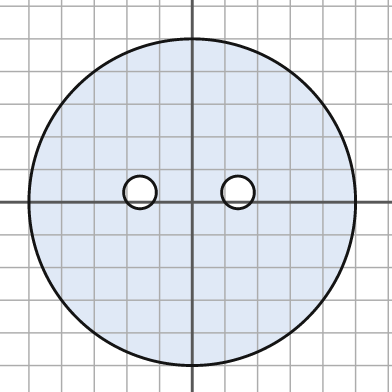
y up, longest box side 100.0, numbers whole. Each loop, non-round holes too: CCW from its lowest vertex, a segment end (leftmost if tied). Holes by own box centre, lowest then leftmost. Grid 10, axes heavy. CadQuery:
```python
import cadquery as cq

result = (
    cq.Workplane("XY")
    .moveTo(0.0, 0.0)
    .circle(50.0)
    .moveTo(-16.0, 3.0)
    .circle(5.0)
    .moveTo(14.0, 3.0)
    .circle(5.0)
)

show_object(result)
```